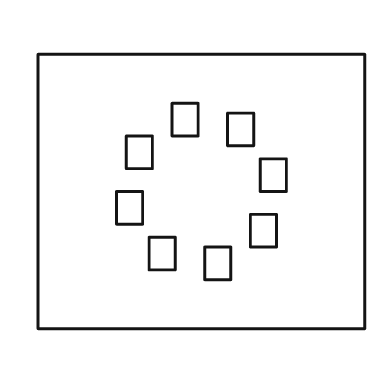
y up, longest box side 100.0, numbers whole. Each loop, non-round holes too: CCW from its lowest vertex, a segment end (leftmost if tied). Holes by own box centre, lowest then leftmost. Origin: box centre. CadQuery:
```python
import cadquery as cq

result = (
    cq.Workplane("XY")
    .moveTo(-50.0, -42.0)
    .lineTo(50.0, -42.0)
    .lineTo(50.0, 42.0)
    .lineTo(-50.0, 42.0)
    .close()
    .moveTo(1.0, -27.0)
    .lineTo(9.0, -27.0)
    .lineTo(9.0, -17.0)
    .lineTo(1.0, -17.0)
    .close()
    .moveTo(-16.0, -24.0)
    .lineTo(-8.0, -24.0)
    .lineTo(-8.0, -14.0)
    .lineTo(-16.0, -14.0)
    .close()
    .moveTo(15.0, -17.0)
    .lineTo(23.0, -17.0)
    .lineTo(23.0, -7.0)
    .lineTo(15.0, -7.0)
    .close()
    .moveTo(-26.0, -10.0)
    .lineTo(-18.0, -10.0)
    .lineTo(-18.0, 0.0)
    .lineTo(-26.0, 0.0)
    .close()
    .moveTo(18.0, 0.0)
    .lineTo(26.0, 0.0)
    .lineTo(26.0, 10.0)
    .lineTo(18.0, 10.0)
    .close()
    .moveTo(-23.0, 7.0)
    .lineTo(-15.0, 7.0)
    .lineTo(-15.0, 17.0)
    .lineTo(-23.0, 17.0)
    .close()
    .moveTo(8.0, 14.0)
    .lineTo(16.0, 14.0)
    .lineTo(16.0, 24.0)
    .lineTo(8.0, 24.0)
    .close()
    .moveTo(-9.0, 17.0)
    .lineTo(-1.0, 17.0)
    .lineTo(-1.0, 27.0)
    .lineTo(-9.0, 27.0)
    .close()
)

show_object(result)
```